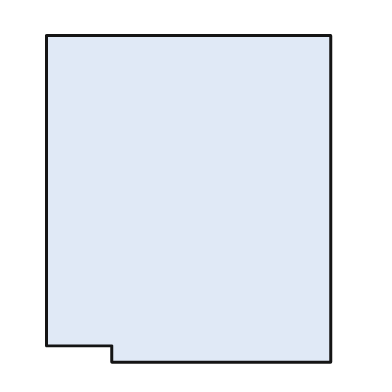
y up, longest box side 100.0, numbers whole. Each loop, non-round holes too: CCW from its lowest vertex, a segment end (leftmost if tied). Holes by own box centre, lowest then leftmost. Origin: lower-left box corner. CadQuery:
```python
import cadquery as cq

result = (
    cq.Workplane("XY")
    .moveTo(20.0, 0.0)
    .lineTo(87.0, 0.0)
    .lineTo(87.0, 100.0)
    .lineTo(0.0, 100.0)
    .lineTo(0.0, 5.0)
    .lineTo(20.0, 5.0)
    .close()
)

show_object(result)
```